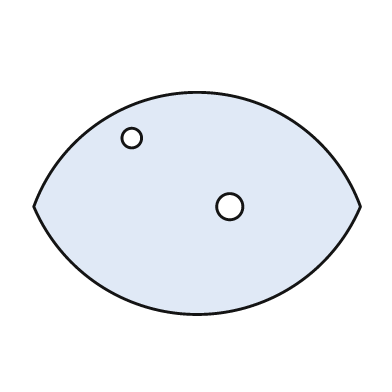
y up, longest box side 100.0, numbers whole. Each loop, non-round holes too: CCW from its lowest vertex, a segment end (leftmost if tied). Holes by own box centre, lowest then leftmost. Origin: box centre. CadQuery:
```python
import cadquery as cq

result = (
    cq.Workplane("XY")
    .moveTo(-50.0, -1.0)
    .threePointArc((0.0, -34.0), (50.0, -1.0))
    .threePointArc((0.0, 34.0), (-50.0, -1.0))
    .close()
    .moveTo(10.0, -1.0)
    .circle(4.0)
    .moveTo(-20.0, 20.0)
    .circle(3.0)
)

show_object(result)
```